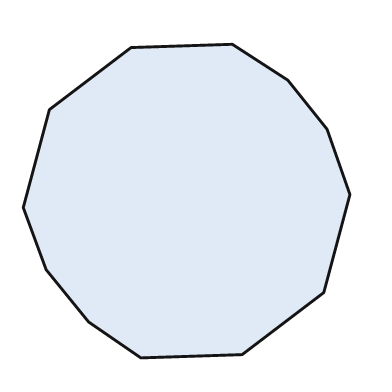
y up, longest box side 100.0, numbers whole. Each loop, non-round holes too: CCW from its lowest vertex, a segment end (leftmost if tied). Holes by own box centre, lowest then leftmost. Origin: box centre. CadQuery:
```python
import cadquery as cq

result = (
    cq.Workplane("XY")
    .moveTo(-14.0, -48.0)
    .lineTo(17.0, -47.0)
    .lineTo(42.0, -28.0)
    .lineTo(50.0, 2.0)
    .lineTo(43.0, 22.0)
    .lineTo(31.0, 37.0)
    .lineTo(14.0, 48.0)
    .lineTo(-17.0, 47.0)
    .lineTo(-42.0, 28.0)
    .lineTo(-50.0, -2.0)
    .lineTo(-43.0, -21.0)
    .lineTo(-30.0, -37.0)
    .close()
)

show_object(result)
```